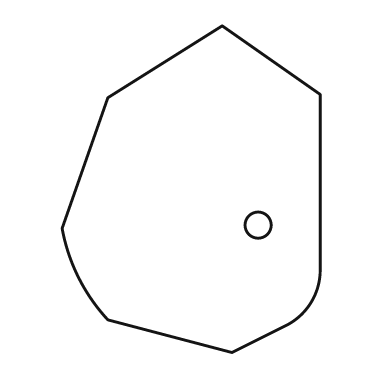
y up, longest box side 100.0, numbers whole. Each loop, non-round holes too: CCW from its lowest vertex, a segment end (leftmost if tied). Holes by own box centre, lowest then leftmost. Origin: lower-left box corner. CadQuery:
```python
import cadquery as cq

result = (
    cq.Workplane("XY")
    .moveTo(52.0, 0.0)
    .lineTo(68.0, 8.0)
    .threePointArc((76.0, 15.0), (79.0, 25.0))
    .lineTo(79.0, 79.0)
    .lineTo(49.0, 100.0)
    .lineTo(14.0, 78.0)
    .lineTo(0.0, 38.0)
    .threePointArc((5.0, 23.0), (14.0, 10.0))
    .close()
    .moveTo(60.0, 39.0)
    .circle(4.0)
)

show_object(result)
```